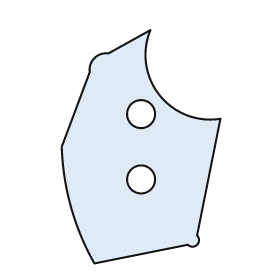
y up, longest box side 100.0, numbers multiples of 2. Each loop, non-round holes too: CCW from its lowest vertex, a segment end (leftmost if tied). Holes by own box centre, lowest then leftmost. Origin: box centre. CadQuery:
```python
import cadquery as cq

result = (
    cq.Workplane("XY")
    .moveTo(-20.0, -50.0)
    .lineTo(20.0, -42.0)
    .threePointArc((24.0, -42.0), (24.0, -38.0))
    .lineTo(34.0, 12.0)
    .threePointArc((8.0, 22.0), (4.0, 50.0))
    .lineTo(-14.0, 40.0)
    .threePointArc((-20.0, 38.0), (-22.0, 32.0))
    .lineTo(-34.0, 0.0)
    .threePointArc((-30.0, -26.0), (-20.0, -50.0))
    .close()
    .moveTo(0.0, -14.0)
    .circle(6.0)
    .moveTo(0.0, 14.0)
    .circle(6.0)
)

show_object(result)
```